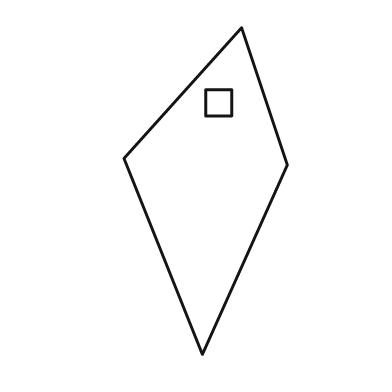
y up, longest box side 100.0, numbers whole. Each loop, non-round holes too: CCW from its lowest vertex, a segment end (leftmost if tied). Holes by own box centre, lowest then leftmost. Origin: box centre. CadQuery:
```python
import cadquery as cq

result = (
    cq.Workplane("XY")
    .moveTo(-1.0, -50.0)
    .lineTo(25.0, 8.0)
    .lineTo(11.0, 50.0)
    .lineTo(-25.0, 10.0)
    .close()
    .moveTo(0.0, 23.0)
    .lineTo(8.0, 23.0)
    .lineTo(8.0, 31.0)
    .lineTo(0.0, 31.0)
    .close()
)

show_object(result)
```